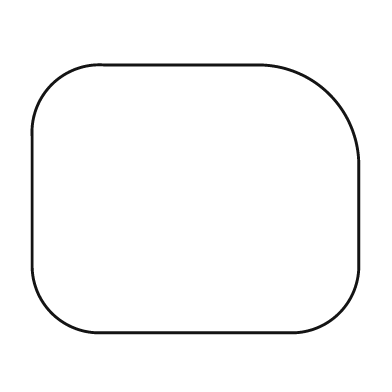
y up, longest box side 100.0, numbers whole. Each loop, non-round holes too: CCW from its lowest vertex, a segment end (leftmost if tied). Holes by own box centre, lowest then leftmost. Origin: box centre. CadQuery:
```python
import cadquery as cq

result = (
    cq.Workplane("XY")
    .moveTo(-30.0, -41.0)
    .lineTo(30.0, -41.0)
    .threePointArc((44.0, -35.0), (50.0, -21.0))
    .lineTo(50.0, 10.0)
    .threePointArc((41.0, 32.0), (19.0, 41.0))
    .lineTo(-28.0, 41.0)
    .threePointArc((-44.0, 35.0), (-50.0, 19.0))
    .lineTo(-50.0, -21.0)
    .threePointArc((-44.0, -35.0), (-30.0, -41.0))
    .close()
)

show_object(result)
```